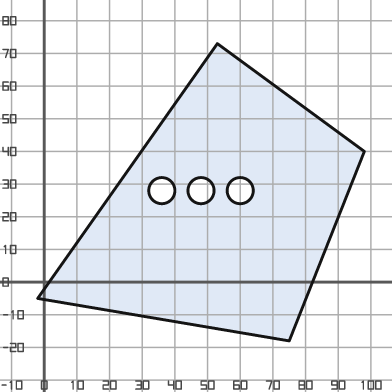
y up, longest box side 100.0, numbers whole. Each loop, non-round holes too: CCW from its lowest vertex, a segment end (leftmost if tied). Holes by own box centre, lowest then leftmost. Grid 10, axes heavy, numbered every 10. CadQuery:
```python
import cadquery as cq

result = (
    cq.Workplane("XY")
    .moveTo(75.0, -18.0)
    .lineTo(98.0, 40.0)
    .lineTo(53.0, 73.0)
    .lineTo(-2.0, -5.0)
    .close()
    .moveTo(36.0, 28.0)
    .circle(4.0)
    .moveTo(48.0, 28.0)
    .circle(4.0)
    .moveTo(60.0, 28.0)
    .circle(4.0)
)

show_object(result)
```